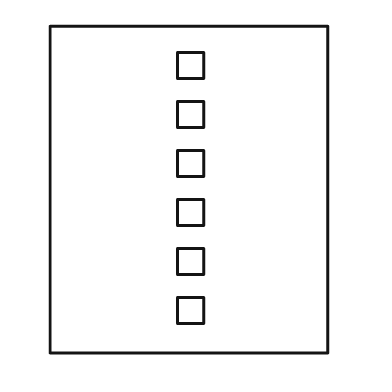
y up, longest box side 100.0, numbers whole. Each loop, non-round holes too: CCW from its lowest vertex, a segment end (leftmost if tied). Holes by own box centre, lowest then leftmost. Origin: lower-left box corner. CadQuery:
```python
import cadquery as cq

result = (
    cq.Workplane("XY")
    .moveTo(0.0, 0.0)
    .lineTo(85.0, 0.0)
    .lineTo(85.0, 100.0)
    .lineTo(0.0, 100.0)
    .close()
    .moveTo(39.0, 9.0)
    .lineTo(47.0, 9.0)
    .lineTo(47.0, 17.0)
    .lineTo(39.0, 17.0)
    .close()
    .moveTo(39.0, 24.0)
    .lineTo(47.0, 24.0)
    .lineTo(47.0, 32.0)
    .lineTo(39.0, 32.0)
    .close()
    .moveTo(39.0, 39.0)
    .lineTo(47.0, 39.0)
    .lineTo(47.0, 47.0)
    .lineTo(39.0, 47.0)
    .close()
    .moveTo(39.0, 54.0)
    .lineTo(47.0, 54.0)
    .lineTo(47.0, 62.0)
    .lineTo(39.0, 62.0)
    .close()
    .moveTo(39.0, 69.0)
    .lineTo(47.0, 69.0)
    .lineTo(47.0, 77.0)
    .lineTo(39.0, 77.0)
    .close()
    .moveTo(39.0, 84.0)
    .lineTo(47.0, 84.0)
    .lineTo(47.0, 92.0)
    .lineTo(39.0, 92.0)
    .close()
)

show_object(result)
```